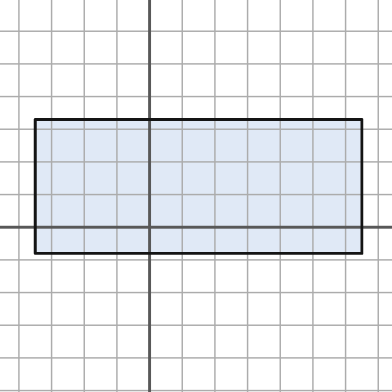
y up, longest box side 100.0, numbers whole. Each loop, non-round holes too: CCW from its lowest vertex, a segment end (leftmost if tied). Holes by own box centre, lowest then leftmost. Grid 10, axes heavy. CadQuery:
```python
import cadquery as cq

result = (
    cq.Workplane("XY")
    .moveTo(-35.0, -8.0)
    .lineTo(65.0, -8.0)
    .lineTo(65.0, 33.0)
    .lineTo(-35.0, 33.0)
    .close()
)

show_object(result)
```